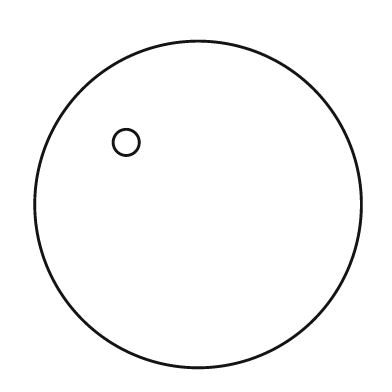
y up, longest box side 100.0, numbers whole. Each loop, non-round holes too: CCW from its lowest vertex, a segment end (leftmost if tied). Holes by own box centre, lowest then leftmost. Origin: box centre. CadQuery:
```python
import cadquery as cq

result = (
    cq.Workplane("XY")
    .moveTo(0.0, 0.0)
    .circle(50.0)
    .moveTo(-22.0, 19.0)
    .circle(4.0)
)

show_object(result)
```